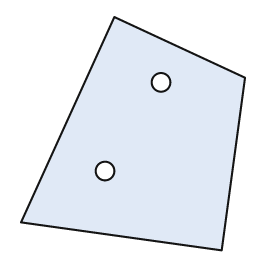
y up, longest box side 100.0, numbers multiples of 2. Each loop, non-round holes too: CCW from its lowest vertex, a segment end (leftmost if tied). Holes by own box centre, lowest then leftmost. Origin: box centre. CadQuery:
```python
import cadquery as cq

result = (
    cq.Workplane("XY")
    .moveTo(38.0, -50.0)
    .lineTo(48.0, 24.0)
    .lineTo(-8.0, 50.0)
    .lineTo(-48.0, -38.0)
    .close()
    .moveTo(-12.0, -16.0)
    .circle(4.0)
    .moveTo(12.0, 22.0)
    .circle(4.0)
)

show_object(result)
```